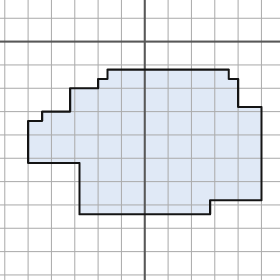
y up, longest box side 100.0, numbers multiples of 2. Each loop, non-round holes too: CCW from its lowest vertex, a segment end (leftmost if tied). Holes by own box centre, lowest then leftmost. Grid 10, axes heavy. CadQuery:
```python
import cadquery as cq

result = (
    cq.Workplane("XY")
    .moveTo(-28.0, -74.0)
    .lineTo(28.0, -74.0)
    .lineTo(28.0, -68.0)
    .lineTo(50.0, -68.0)
    .lineTo(50.0, -28.0)
    .lineTo(40.0, -28.0)
    .lineTo(40.0, -16.0)
    .lineTo(36.0, -16.0)
    .lineTo(36.0, -12.0)
    .lineTo(-16.0, -12.0)
    .lineTo(-16.0, -16.0)
    .lineTo(-20.0, -16.0)
    .lineTo(-20.0, -20.0)
    .lineTo(-32.0, -20.0)
    .lineTo(-32.0, -30.0)
    .lineTo(-44.0, -30.0)
    .lineTo(-44.0, -34.0)
    .lineTo(-50.0, -34.0)
    .lineTo(-50.0, -52.0)
    .lineTo(-28.0, -52.0)
    .close()
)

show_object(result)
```